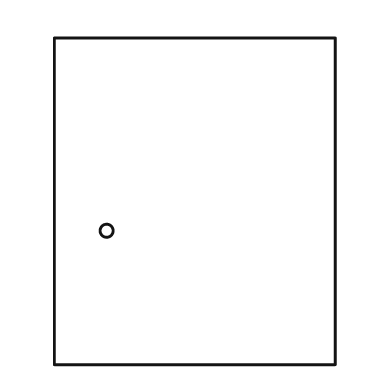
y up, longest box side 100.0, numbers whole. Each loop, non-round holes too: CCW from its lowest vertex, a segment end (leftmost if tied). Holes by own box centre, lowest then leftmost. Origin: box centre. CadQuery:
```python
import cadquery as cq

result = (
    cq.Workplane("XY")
    .moveTo(-43.0, -50.0)
    .lineTo(43.0, -50.0)
    .lineTo(43.0, 50.0)
    .lineTo(-43.0, 50.0)
    .close()
    .moveTo(-27.0, -9.0)
    .circle(2.0)
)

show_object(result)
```